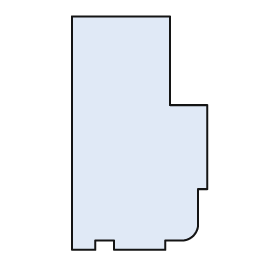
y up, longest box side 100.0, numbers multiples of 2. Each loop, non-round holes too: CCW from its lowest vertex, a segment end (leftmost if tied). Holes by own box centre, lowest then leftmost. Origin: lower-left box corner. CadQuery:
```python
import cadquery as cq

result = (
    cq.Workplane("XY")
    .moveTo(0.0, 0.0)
    .lineTo(10.0, 0.0)
    .lineTo(10.0, 4.0)
    .lineTo(18.0, 4.0)
    .lineTo(18.0, 0.0)
    .lineTo(40.0, 0.0)
    .lineTo(40.0, 4.0)
    .lineTo(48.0, 4.0)
    .threePointArc((52.0, 6.0), (54.0, 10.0))
    .lineTo(54.0, 26.0)
    .lineTo(58.0, 26.0)
    .lineTo(58.0, 62.0)
    .lineTo(42.0, 62.0)
    .lineTo(42.0, 100.0)
    .lineTo(0.0, 100.0)
    .close()
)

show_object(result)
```